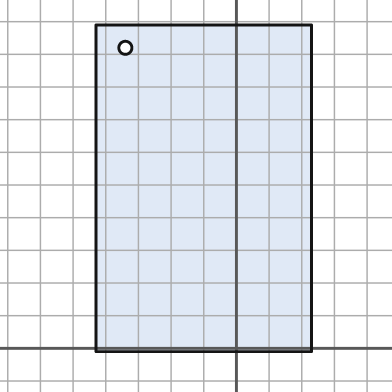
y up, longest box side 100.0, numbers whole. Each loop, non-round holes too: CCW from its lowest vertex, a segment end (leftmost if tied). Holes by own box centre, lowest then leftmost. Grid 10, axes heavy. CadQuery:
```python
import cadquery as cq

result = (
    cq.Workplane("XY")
    .moveTo(-43.0, -1.0)
    .lineTo(23.0, -1.0)
    .lineTo(23.0, 99.0)
    .lineTo(-43.0, 99.0)
    .close()
    .moveTo(-34.0, 92.0)
    .circle(2.0)
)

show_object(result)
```